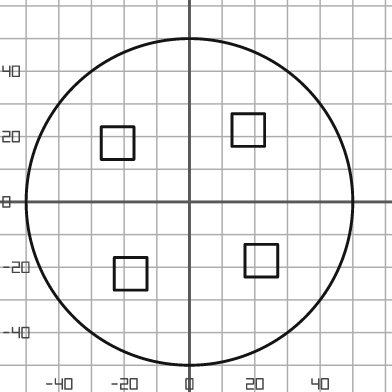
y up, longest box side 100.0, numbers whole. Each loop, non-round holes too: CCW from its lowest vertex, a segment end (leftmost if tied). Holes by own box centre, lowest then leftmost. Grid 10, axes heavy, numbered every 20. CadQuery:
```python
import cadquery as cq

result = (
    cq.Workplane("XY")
    .moveTo(0.0, 0.0)
    .circle(50.0)
    .moveTo(-23.0, -27.0)
    .lineTo(-13.0, -27.0)
    .lineTo(-13.0, -17.0)
    .lineTo(-23.0, -17.0)
    .close()
    .moveTo(17.0, -23.0)
    .lineTo(27.0, -23.0)
    .lineTo(27.0, -13.0)
    .lineTo(17.0, -13.0)
    .close()
    .moveTo(-27.0, 13.0)
    .lineTo(-17.0, 13.0)
    .lineTo(-17.0, 23.0)
    .lineTo(-27.0, 23.0)
    .close()
    .moveTo(13.0, 17.0)
    .lineTo(23.0, 17.0)
    .lineTo(23.0, 27.0)
    .lineTo(13.0, 27.0)
    .close()
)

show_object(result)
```